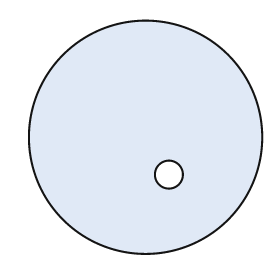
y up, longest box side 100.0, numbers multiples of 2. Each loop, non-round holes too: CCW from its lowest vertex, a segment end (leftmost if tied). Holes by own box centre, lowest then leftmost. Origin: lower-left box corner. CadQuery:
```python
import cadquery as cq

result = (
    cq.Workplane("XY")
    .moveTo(50.0, 50.0)
    .circle(50.0)
    .moveTo(60.0, 34.0)
    .circle(6.0)
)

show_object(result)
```